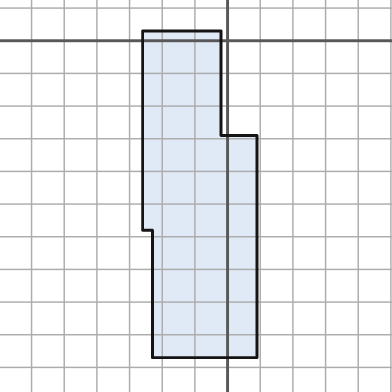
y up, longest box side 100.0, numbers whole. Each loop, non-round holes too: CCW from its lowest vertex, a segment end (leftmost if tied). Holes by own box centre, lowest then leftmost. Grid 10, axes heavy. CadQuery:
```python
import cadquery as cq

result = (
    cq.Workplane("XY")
    .moveTo(-23.0, -97.0)
    .lineTo(9.0, -97.0)
    .lineTo(9.0, -29.0)
    .lineTo(-2.0, -29.0)
    .lineTo(-2.0, 3.0)
    .lineTo(-26.0, 3.0)
    .lineTo(-26.0, -58.0)
    .lineTo(-23.0, -58.0)
    .close()
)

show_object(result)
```